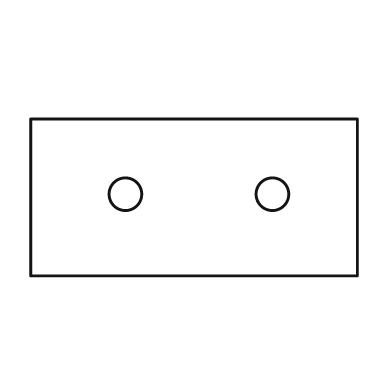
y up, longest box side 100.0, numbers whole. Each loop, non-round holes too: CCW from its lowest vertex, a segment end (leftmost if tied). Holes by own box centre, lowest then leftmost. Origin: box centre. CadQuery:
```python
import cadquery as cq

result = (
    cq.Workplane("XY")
    .moveTo(-50.0, -24.0)
    .lineTo(50.0, -24.0)
    .lineTo(50.0, 24.0)
    .lineTo(-50.0, 24.0)
    .close()
    .moveTo(-21.0, 1.0)
    .circle(5.0)
    .moveTo(24.0, 1.0)
    .circle(5.0)
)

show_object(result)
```